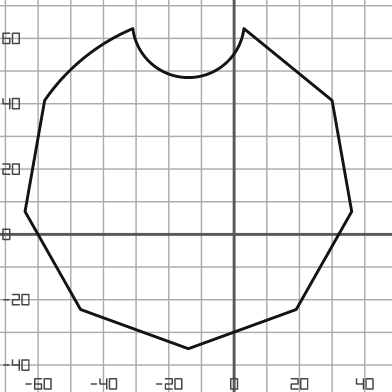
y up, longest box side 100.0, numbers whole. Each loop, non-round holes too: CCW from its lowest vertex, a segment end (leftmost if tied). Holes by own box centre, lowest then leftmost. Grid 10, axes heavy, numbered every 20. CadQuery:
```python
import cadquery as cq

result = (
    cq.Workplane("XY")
    .moveTo(-14.0, -35.0)
    .lineTo(19.0, -23.0)
    .lineTo(36.0, 7.0)
    .lineTo(30.0, 41.0)
    .lineTo(3.0, 63.0)
    .threePointArc((-14.0, 48.0), (-31.0, 63.0))
    .threePointArc((-46.0, 54.0), (-58.0, 41.0))
    .lineTo(-64.0, 7.0)
    .lineTo(-47.0, -23.0)
    .close()
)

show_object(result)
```